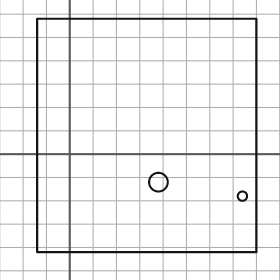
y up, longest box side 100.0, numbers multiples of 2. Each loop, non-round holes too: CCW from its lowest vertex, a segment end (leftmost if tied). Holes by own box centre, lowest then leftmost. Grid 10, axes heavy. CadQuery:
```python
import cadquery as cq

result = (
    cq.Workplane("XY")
    .moveTo(-14.0, -42.0)
    .lineTo(80.0, -42.0)
    .lineTo(80.0, 58.0)
    .lineTo(-14.0, 58.0)
    .close()
    .moveTo(74.0, -18.0)
    .circle(2.0)
    .moveTo(38.0, -12.0)
    .circle(4.0)
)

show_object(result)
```